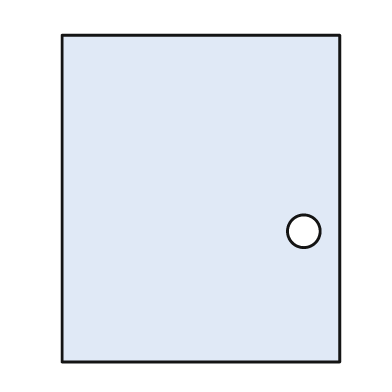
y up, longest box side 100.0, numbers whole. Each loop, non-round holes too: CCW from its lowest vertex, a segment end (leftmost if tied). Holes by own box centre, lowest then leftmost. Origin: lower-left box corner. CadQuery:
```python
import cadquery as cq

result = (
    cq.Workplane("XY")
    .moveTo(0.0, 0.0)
    .lineTo(85.0, 0.0)
    .lineTo(85.0, 100.0)
    .lineTo(0.0, 100.0)
    .close()
    .moveTo(74.0, 40.0)
    .circle(5.0)
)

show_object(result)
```